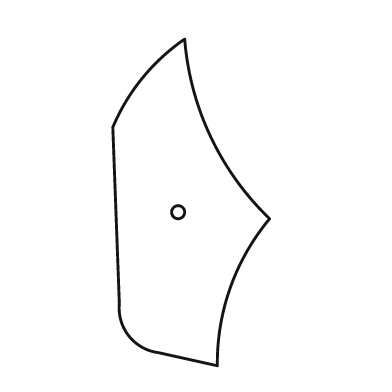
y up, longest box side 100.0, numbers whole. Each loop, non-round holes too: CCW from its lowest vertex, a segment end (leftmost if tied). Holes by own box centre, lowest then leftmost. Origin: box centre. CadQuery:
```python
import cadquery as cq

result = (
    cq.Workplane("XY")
    .moveTo(8.0, -50.0)
    .threePointArc((12.0, -26.0), (24.0, -5.0))
    .threePointArc((6.0, 20.0), (-2.0, 50.0))
    .threePointArc((-15.0, 38.0), (-24.0, 23.0))
    .lineTo(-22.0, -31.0)
    .threePointArc((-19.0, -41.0), (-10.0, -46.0))
    .close()
    .moveTo(-4.0, -3.0)
    .circle(2.0)
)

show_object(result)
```